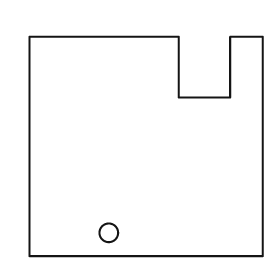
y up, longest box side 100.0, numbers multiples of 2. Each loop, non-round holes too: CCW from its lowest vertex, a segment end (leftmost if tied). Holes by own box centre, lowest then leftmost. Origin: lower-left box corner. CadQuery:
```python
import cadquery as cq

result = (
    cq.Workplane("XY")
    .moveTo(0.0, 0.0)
    .lineTo(100.0, 0.0)
    .lineTo(100.0, 94.0)
    .lineTo(86.0, 94.0)
    .lineTo(86.0, 68.0)
    .lineTo(64.0, 68.0)
    .lineTo(64.0, 94.0)
    .lineTo(0.0, 94.0)
    .close()
    .moveTo(34.0, 10.0)
    .circle(4.0)
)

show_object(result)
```